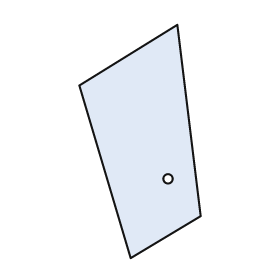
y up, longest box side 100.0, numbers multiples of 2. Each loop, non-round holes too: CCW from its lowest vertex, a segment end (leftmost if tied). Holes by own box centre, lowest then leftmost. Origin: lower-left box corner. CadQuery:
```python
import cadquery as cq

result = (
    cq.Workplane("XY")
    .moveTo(22.0, 0.0)
    .lineTo(52.0, 18.0)
    .lineTo(42.0, 100.0)
    .lineTo(0.0, 74.0)
    .close()
    .moveTo(38.0, 34.0)
    .circle(2.0)
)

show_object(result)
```